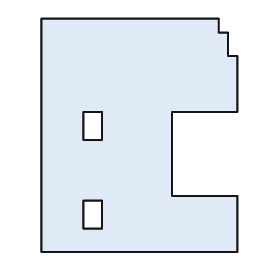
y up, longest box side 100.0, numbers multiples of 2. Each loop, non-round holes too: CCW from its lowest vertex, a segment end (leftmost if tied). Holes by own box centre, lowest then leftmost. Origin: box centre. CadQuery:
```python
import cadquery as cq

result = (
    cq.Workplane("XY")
    .moveTo(-42.0, -50.0)
    .lineTo(42.0, -50.0)
    .lineTo(42.0, -26.0)
    .lineTo(14.0, -26.0)
    .lineTo(14.0, 10.0)
    .lineTo(42.0, 10.0)
    .lineTo(42.0, 34.0)
    .lineTo(38.0, 34.0)
    .lineTo(38.0, 44.0)
    .lineTo(34.0, 44.0)
    .lineTo(34.0, 50.0)
    .lineTo(-42.0, 50.0)
    .close()
    .moveTo(-24.0, -40.0)
    .lineTo(-16.0, -40.0)
    .lineTo(-16.0, -28.0)
    .lineTo(-24.0, -28.0)
    .close()
    .moveTo(-24.0, -2.0)
    .lineTo(-16.0, -2.0)
    .lineTo(-16.0, 10.0)
    .lineTo(-24.0, 10.0)
    .close()
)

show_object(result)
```